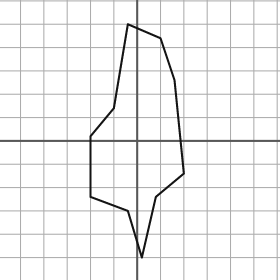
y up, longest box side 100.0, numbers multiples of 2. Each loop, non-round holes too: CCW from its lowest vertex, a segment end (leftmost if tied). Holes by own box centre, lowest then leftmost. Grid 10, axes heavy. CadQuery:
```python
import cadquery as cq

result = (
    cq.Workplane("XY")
    .moveTo(2.0, -50.0)
    .lineTo(8.0, -24.0)
    .lineTo(20.0, -14.0)
    .lineTo(16.0, 26.0)
    .lineTo(10.0, 44.0)
    .lineTo(-4.0, 50.0)
    .lineTo(-10.0, 14.0)
    .lineTo(-20.0, 2.0)
    .lineTo(-20.0, -24.0)
    .lineTo(-4.0, -30.0)
    .close()
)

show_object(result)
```